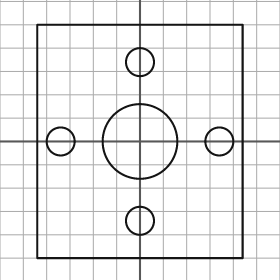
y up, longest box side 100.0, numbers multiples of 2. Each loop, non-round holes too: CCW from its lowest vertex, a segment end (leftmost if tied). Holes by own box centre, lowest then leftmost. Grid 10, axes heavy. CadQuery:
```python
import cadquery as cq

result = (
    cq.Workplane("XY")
    .moveTo(-44.0, -50.0)
    .lineTo(44.0, -50.0)
    .lineTo(44.0, 50.0)
    .lineTo(-44.0, 50.0)
    .close()
    .moveTo(0.0, -34.0)
    .circle(6.0)
    .moveTo(-34.0, 0.0)
    .circle(6.0)
    .moveTo(0.0, 0.0)
    .circle(16.0)
    .moveTo(34.0, 0.0)
    .circle(6.0)
    .moveTo(0.0, 34.0)
    .circle(6.0)
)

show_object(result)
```